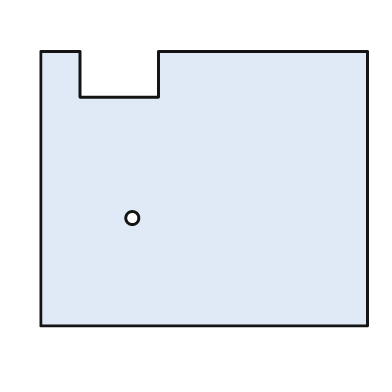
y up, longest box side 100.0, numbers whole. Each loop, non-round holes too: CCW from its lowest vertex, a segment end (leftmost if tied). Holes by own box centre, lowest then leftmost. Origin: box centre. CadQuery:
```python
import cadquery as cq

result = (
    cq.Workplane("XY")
    .moveTo(-50.0, -42.0)
    .lineTo(50.0, -42.0)
    .lineTo(50.0, 42.0)
    .lineTo(-14.0, 42.0)
    .lineTo(-14.0, 28.0)
    .lineTo(-38.0, 28.0)
    .lineTo(-38.0, 42.0)
    .lineTo(-50.0, 42.0)
    .close()
    .moveTo(-22.0, -9.0)
    .circle(2.0)
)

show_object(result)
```